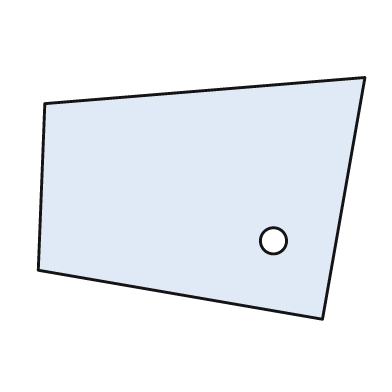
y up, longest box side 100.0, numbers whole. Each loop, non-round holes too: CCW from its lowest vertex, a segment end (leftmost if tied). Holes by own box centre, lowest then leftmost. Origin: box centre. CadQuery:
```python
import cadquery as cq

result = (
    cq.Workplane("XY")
    .moveTo(37.0, -37.0)
    .lineTo(50.0, 37.0)
    .lineTo(-48.0, 29.0)
    .lineTo(-50.0, -22.0)
    .close()
    .moveTo(22.0, -13.0)
    .circle(4.0)
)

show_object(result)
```